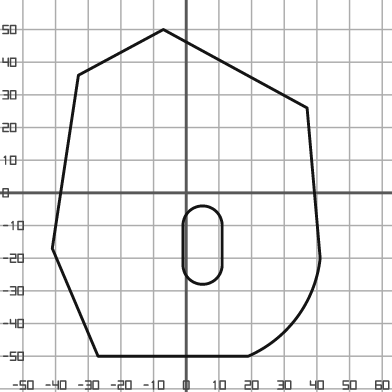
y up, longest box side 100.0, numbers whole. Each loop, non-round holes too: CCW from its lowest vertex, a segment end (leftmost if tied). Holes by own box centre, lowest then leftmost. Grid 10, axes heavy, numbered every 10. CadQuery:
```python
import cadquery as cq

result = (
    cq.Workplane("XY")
    .moveTo(-27.0, -50.0)
    .lineTo(19.0, -50.0)
    .threePointArc((34.0, -38.0), (41.0, -20.0))
    .lineTo(37.0, 26.0)
    .lineTo(-7.0, 50.0)
    .lineTo(-33.0, 36.0)
    .lineTo(-41.0, -17.0)
    .close()
    .moveTo(-1.0, -22.0)
    .threePointArc((5.0, -28.0), (11.0, -22.0))
    .lineTo(11.0, -10.0)
    .threePointArc((5.0, -4.0), (-1.0, -10.0))
    .close()
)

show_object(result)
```